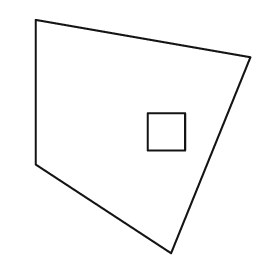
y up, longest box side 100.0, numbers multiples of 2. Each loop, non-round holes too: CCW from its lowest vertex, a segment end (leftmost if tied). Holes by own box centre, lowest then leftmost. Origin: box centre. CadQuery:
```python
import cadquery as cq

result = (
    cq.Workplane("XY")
    .moveTo(12.0, -50.0)
    .lineTo(46.0, 34.0)
    .lineTo(-46.0, 50.0)
    .lineTo(-46.0, -12.0)
    .close()
    .moveTo(2.0, -6.0)
    .lineTo(18.0, -6.0)
    .lineTo(18.0, 10.0)
    .lineTo(2.0, 10.0)
    .close()
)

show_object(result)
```